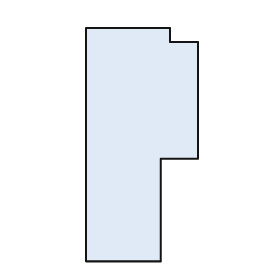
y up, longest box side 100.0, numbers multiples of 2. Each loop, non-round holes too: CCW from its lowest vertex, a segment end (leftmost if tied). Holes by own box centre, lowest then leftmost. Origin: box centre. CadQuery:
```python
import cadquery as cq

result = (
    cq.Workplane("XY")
    .moveTo(-24.0, -50.0)
    .lineTo(8.0, -50.0)
    .lineTo(8.0, -6.0)
    .lineTo(24.0, -6.0)
    .lineTo(24.0, 44.0)
    .lineTo(12.0, 44.0)
    .lineTo(12.0, 50.0)
    .lineTo(-24.0, 50.0)
    .close()
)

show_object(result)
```